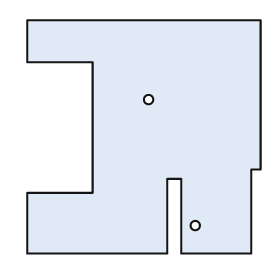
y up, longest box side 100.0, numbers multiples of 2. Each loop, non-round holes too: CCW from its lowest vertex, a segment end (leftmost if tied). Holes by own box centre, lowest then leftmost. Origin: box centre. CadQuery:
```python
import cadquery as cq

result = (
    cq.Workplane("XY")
    .moveTo(-50.0, -50.0)
    .lineTo(10.0, -50.0)
    .lineTo(10.0, -18.0)
    .lineTo(16.0, -18.0)
    .lineTo(16.0, -50.0)
    .lineTo(46.0, -50.0)
    .lineTo(46.0, -14.0)
    .lineTo(50.0, -14.0)
    .lineTo(50.0, 50.0)
    .lineTo(-50.0, 50.0)
    .lineTo(-50.0, 32.0)
    .lineTo(-22.0, 32.0)
    .lineTo(-22.0, -24.0)
    .lineTo(-50.0, -24.0)
    .close()
    .moveTo(22.0, -38.0)
    .circle(2.0)
    .moveTo(2.0, 16.0)
    .circle(2.0)
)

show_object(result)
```